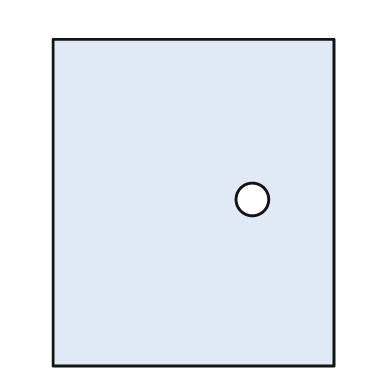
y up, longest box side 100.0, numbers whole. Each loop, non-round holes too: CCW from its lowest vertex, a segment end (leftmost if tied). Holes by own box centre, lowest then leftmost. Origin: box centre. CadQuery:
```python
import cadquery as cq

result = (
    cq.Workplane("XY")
    .moveTo(-43.0, -50.0)
    .lineTo(43.0, -50.0)
    .lineTo(43.0, 50.0)
    .lineTo(-43.0, 50.0)
    .close()
    .moveTo(18.0, 1.0)
    .circle(5.0)
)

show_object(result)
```